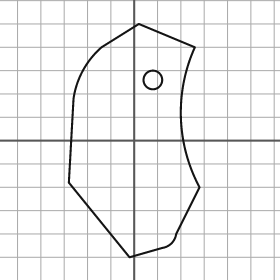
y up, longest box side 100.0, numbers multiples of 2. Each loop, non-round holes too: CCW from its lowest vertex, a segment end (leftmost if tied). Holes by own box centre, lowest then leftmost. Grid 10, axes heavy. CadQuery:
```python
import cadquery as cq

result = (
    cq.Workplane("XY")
    .moveTo(-2.0, -50.0)
    .lineTo(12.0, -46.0)
    .threePointArc((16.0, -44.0), (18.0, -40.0))
    .lineTo(28.0, -20.0)
    .threePointArc((20.0, 10.0), (26.0, 40.0))
    .lineTo(2.0, 50.0)
    .lineTo(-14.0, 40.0)
    .threePointArc((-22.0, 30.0), (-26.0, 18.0))
    .lineTo(-28.0, -18.0)
    .close()
    .moveTo(8.0, 26.0)
    .circle(4.0)
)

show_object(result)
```